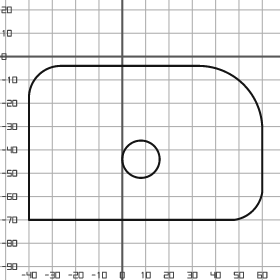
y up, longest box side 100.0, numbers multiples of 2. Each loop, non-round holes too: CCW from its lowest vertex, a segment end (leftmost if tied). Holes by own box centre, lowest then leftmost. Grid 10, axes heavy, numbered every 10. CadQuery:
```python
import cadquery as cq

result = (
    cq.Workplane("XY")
    .moveTo(-40.0, -70.0)
    .lineTo(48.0, -70.0)
    .threePointArc((56.0, -66.0), (60.0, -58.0))
    .lineTo(60.0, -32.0)
    .threePointArc((52.0, -12.0), (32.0, -4.0))
    .lineTo(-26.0, -4.0)
    .threePointArc((-36.0, -8.0), (-40.0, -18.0))
    .close()
    .moveTo(8.0, -44.0)
    .circle(8.0)
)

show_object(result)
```